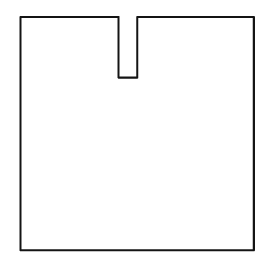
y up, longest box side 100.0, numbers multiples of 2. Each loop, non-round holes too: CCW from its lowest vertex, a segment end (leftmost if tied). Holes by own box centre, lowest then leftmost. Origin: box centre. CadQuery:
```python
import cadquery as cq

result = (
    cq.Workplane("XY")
    .moveTo(-50.0, -50.0)
    .lineTo(50.0, -50.0)
    .lineTo(50.0, 50.0)
    .lineTo(0.0, 50.0)
    .lineTo(0.0, 24.0)
    .lineTo(-8.0, 24.0)
    .lineTo(-8.0, 50.0)
    .lineTo(-50.0, 50.0)
    .close()
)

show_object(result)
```